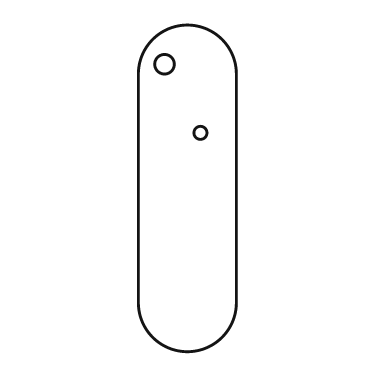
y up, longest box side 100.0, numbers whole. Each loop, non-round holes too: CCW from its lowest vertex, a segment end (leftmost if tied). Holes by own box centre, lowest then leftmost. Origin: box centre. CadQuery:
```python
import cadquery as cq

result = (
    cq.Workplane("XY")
    .moveTo(-15.0, -35.0)
    .threePointArc((0.0, -50.0), (15.0, -35.0))
    .lineTo(15.0, 35.0)
    .threePointArc((0.0, 50.0), (-15.0, 35.0))
    .close()
    .moveTo(4.0, 17.0)
    .circle(2.0)
    .moveTo(-7.0, 38.0)
    .circle(3.0)
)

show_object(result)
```